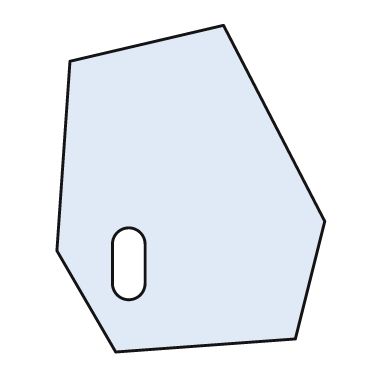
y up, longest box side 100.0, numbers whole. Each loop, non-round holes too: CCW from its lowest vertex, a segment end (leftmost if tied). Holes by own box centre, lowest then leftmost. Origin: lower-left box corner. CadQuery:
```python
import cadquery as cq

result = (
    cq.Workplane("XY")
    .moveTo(18.0, 0.0)
    .lineTo(73.0, 4.0)
    .lineTo(82.0, 40.0)
    .lineTo(51.0, 100.0)
    .lineTo(4.0, 89.0)
    .lineTo(0.0, 31.0)
    .close()
    .moveTo(17.0, 21.0)
    .threePointArc((22.0, 16.0), (27.0, 21.0))
    .lineTo(27.0, 33.0)
    .threePointArc((22.0, 38.0), (17.0, 33.0))
    .close()
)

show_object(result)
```